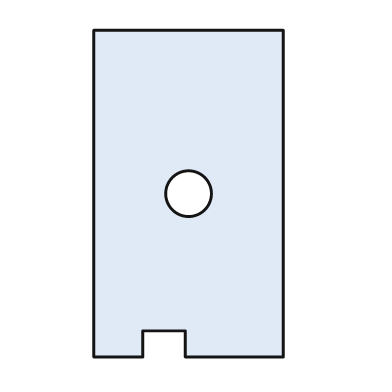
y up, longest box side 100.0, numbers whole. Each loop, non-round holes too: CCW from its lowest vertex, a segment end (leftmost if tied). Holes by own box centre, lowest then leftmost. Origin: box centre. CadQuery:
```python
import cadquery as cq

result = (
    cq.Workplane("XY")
    .moveTo(-29.0, -50.0)
    .lineTo(-14.0, -50.0)
    .lineTo(-14.0, -42.0)
    .lineTo(-1.0, -42.0)
    .lineTo(-1.0, -50.0)
    .lineTo(29.0, -50.0)
    .lineTo(29.0, 50.0)
    .lineTo(-29.0, 50.0)
    .close()
    .moveTo(0.0, 0.0)
    .circle(7.0)
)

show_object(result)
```